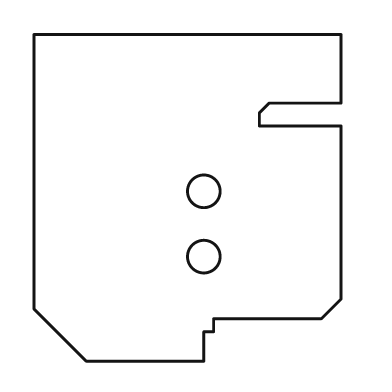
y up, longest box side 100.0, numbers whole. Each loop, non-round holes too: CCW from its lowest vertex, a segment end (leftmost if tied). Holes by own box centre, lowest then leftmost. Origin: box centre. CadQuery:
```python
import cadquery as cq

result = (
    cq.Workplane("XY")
    .moveTo(-31.0, -50.0)
    .lineTo(5.0, -50.0)
    .lineTo(5.0, -41.0)
    .lineTo(8.0, -41.0)
    .lineTo(8.0, -37.0)
    .lineTo(41.0, -37.0)
    .lineTo(47.0, -31.0)
    .lineTo(47.0, 22.0)
    .lineTo(22.0, 22.0)
    .lineTo(22.0, 26.0)
    .lineTo(25.0, 29.0)
    .lineTo(47.0, 29.0)
    .lineTo(47.0, 50.0)
    .lineTo(-47.0, 50.0)
    .lineTo(-47.0, -34.0)
    .close()
    .moveTo(5.0, -18.0)
    .circle(5.0)
    .moveTo(5.0, 2.0)
    .circle(5.0)
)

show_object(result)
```